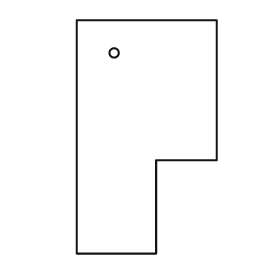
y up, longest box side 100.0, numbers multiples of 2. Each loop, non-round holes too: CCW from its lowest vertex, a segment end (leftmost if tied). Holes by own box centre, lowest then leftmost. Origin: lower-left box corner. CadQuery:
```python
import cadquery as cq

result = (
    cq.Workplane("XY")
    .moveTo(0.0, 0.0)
    .lineTo(34.0, 0.0)
    .lineTo(34.0, 40.0)
    .lineTo(60.0, 40.0)
    .lineTo(60.0, 100.0)
    .lineTo(0.0, 100.0)
    .close()
    .moveTo(16.0, 86.0)
    .circle(2.0)
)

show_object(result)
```